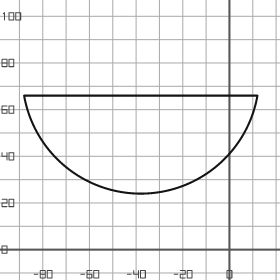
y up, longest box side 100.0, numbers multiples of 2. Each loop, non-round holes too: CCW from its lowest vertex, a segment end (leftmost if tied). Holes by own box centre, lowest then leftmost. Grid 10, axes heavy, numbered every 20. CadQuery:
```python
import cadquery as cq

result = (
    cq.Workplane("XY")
    .moveTo(-88.0, 66.0)
    .threePointArc((-38.0, 24.0), (12.0, 66.0))
    .close()
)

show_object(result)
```